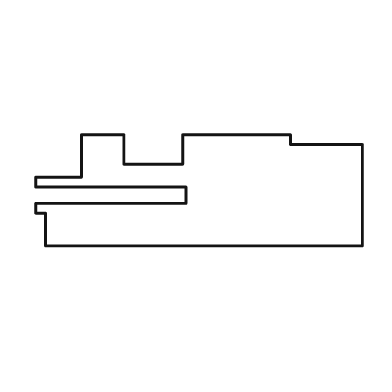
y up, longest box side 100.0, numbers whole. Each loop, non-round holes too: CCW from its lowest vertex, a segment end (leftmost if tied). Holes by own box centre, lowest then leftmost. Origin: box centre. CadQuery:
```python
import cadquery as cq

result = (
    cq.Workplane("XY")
    .moveTo(-47.0, -17.0)
    .lineTo(50.0, -17.0)
    .lineTo(50.0, 14.0)
    .lineTo(28.0, 14.0)
    .lineTo(28.0, 17.0)
    .lineTo(-5.0, 17.0)
    .lineTo(-5.0, 8.0)
    .lineTo(-23.0, 8.0)
    .lineTo(-23.0, 17.0)
    .lineTo(-36.0, 17.0)
    .lineTo(-36.0, 4.0)
    .lineTo(-50.0, 4.0)
    .lineTo(-50.0, 1.0)
    .lineTo(-4.0, 1.0)
    .lineTo(-4.0, -4.0)
    .lineTo(-50.0, -4.0)
    .lineTo(-50.0, -7.0)
    .lineTo(-47.0, -7.0)
    .close()
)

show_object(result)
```